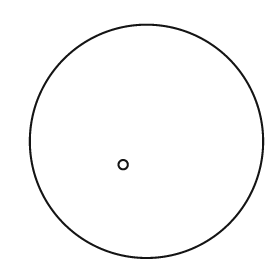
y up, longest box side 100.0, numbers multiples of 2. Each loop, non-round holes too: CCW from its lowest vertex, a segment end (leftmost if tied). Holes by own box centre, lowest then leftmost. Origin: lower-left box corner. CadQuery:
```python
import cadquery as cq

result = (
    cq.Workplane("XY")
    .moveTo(50.0, 50.0)
    .circle(50.0)
    .moveTo(40.0, 40.0)
    .circle(2.0)
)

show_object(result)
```